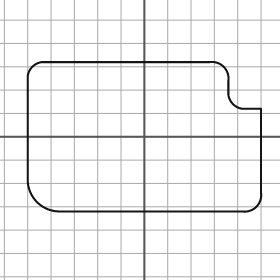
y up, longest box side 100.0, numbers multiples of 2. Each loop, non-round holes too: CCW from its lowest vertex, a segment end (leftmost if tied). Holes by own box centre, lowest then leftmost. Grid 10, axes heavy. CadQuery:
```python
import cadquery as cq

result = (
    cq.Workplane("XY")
    .moveTo(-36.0, -32.0)
    .lineTo(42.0, -32.0)
    .threePointArc((48.0, -30.0), (50.0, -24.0))
    .lineTo(50.0, 12.0)
    .lineTo(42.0, 12.0)
    .threePointArc((38.0, 14.0), (36.0, 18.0))
    .lineTo(36.0, 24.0)
    .threePointArc((34.0, 30.0), (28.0, 32.0))
    .lineTo(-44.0, 32.0)
    .threePointArc((-48.0, 30.0), (-50.0, 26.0))
    .lineTo(-50.0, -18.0)
    .threePointArc((-46.0, -28.0), (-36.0, -32.0))
    .close()
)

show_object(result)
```